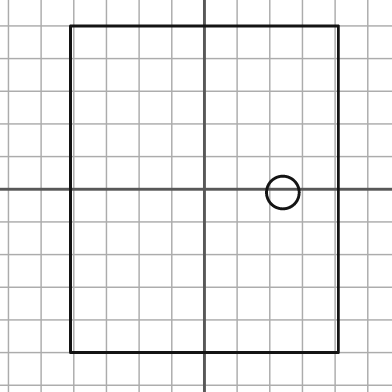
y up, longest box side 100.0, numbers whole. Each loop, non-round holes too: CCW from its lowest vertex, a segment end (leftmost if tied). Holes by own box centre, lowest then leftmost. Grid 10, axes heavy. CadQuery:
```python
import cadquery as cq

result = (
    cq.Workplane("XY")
    .moveTo(-41.0, -50.0)
    .lineTo(41.0, -50.0)
    .lineTo(41.0, 50.0)
    .lineTo(-41.0, 50.0)
    .close()
    .moveTo(24.0, -1.0)
    .circle(5.0)
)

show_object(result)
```